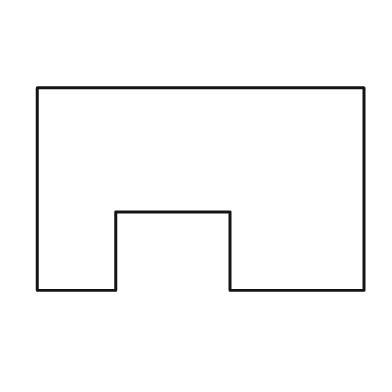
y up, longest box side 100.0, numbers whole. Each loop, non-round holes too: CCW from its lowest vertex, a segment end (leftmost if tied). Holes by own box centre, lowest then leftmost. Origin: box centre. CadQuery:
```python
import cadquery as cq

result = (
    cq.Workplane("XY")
    .moveTo(-50.0, -31.0)
    .lineTo(-26.0, -31.0)
    .lineTo(-26.0, -7.0)
    .lineTo(9.0, -7.0)
    .lineTo(9.0, -31.0)
    .lineTo(50.0, -31.0)
    .lineTo(50.0, 31.0)
    .lineTo(-50.0, 31.0)
    .close()
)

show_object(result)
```